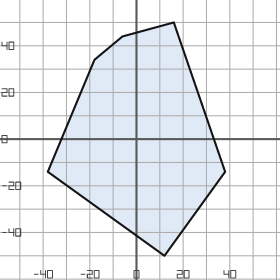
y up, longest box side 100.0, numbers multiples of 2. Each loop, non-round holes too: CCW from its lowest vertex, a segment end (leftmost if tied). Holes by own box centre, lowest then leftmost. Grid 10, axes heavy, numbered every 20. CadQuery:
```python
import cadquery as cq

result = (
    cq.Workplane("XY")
    .moveTo(12.0, -50.0)
    .lineTo(38.0, -14.0)
    .lineTo(16.0, 50.0)
    .lineTo(-6.0, 44.0)
    .lineTo(-18.0, 34.0)
    .lineTo(-38.0, -14.0)
    .close()
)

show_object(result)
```